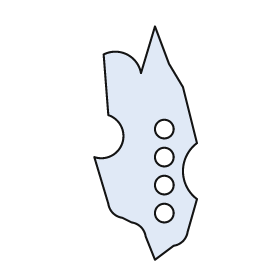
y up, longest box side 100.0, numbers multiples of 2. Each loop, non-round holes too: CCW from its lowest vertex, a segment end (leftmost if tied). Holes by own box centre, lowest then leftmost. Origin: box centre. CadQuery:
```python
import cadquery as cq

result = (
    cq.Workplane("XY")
    .moveTo(4.0, -50.0)
    .lineTo(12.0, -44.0)
    .threePointArc((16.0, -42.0), (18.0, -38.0))
    .lineTo(22.0, -24.0)
    .threePointArc((16.0, -12.0), (22.0, 0.0))
    .lineTo(16.0, 24.0)
    .lineTo(10.0, 34.0)
    .lineTo(4.0, 50.0)
    .lineTo(-2.0, 30.0)
    .threePointArc((-8.0, 38.0), (-18.0, 38.0))
    .lineTo(-16.0, 12.0)
    .threePointArc((-10.0, 0.0), (-22.0, -6.0))
    .lineTo(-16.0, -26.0)
    .threePointArc((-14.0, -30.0), (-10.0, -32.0))
    .lineTo(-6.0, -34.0)
    .threePointArc((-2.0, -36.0), (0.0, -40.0))
    .close()
    .moveTo(8.0, -30.0)
    .circle(4.0)
    .moveTo(8.0, -18.0)
    .circle(4.0)
    .moveTo(8.0, -6.0)
    .circle(4.0)
    .moveTo(8.0, 6.0)
    .circle(4.0)
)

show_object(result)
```